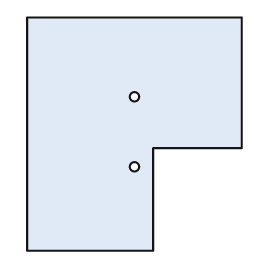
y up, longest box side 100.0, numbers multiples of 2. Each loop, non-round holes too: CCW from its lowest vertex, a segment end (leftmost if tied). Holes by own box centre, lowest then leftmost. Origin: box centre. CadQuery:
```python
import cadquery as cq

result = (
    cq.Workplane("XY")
    .moveTo(-46.0, -50.0)
    .lineTo(8.0, -50.0)
    .lineTo(8.0, -6.0)
    .lineTo(46.0, -6.0)
    .lineTo(46.0, 50.0)
    .lineTo(-46.0, 50.0)
    .close()
    .moveTo(0.0, -14.0)
    .circle(2.0)
    .moveTo(0.0, 16.0)
    .circle(2.0)
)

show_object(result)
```